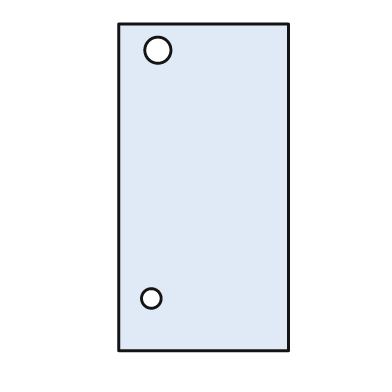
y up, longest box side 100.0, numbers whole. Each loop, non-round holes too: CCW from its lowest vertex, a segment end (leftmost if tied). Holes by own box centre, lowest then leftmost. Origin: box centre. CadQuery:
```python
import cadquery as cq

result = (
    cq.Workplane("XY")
    .moveTo(-26.0, -50.0)
    .lineTo(26.0, -50.0)
    .lineTo(26.0, 50.0)
    .lineTo(-26.0, 50.0)
    .close()
    .moveTo(-16.0, -34.0)
    .circle(3.0)
    .moveTo(-14.0, 42.0)
    .circle(4.0)
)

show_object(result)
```